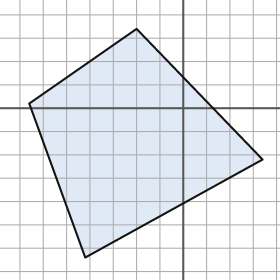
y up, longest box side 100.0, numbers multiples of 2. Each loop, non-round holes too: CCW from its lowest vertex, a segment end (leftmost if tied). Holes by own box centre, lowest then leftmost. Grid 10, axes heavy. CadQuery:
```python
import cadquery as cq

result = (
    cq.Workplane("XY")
    .moveTo(-42.0, -64.0)
    .lineTo(34.0, -22.0)
    .lineTo(-20.0, 34.0)
    .lineTo(-66.0, 2.0)
    .close()
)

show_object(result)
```